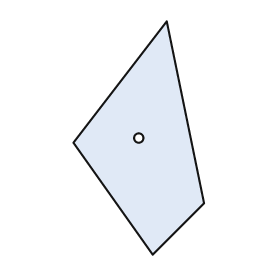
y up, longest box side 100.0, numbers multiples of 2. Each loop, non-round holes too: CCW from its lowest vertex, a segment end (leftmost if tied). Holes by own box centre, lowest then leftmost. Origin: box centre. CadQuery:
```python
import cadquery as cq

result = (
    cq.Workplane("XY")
    .moveTo(6.0, -50.0)
    .lineTo(28.0, -28.0)
    .lineTo(12.0, 50.0)
    .lineTo(-28.0, -2.0)
    .close()
    .moveTo(0.0, 0.0)
    .circle(2.0)
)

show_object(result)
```